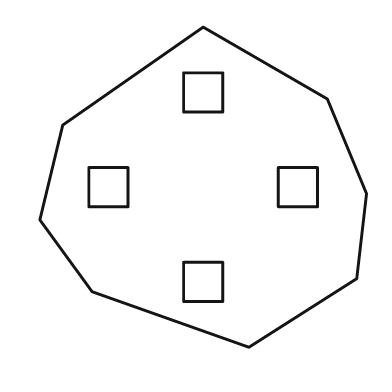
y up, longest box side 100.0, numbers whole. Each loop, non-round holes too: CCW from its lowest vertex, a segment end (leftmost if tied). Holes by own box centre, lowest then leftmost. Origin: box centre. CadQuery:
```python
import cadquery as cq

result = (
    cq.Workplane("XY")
    .moveTo(14.0, -49.0)
    .lineTo(47.0, -28.0)
    .lineTo(50.0, -2.0)
    .lineTo(38.0, 27.0)
    .lineTo(0.0, 49.0)
    .lineTo(-43.0, 19.0)
    .lineTo(-50.0, -10.0)
    .lineTo(-34.0, -32.0)
    .close()
    .moveTo(-6.0, -35.0)
    .lineTo(6.0, -35.0)
    .lineTo(6.0, -23.0)
    .lineTo(-6.0, -23.0)
    .close()
    .moveTo(-35.0, -6.0)
    .lineTo(-23.0, -6.0)
    .lineTo(-23.0, 6.0)
    .lineTo(-35.0, 6.0)
    .close()
    .moveTo(23.0, -6.0)
    .lineTo(35.0, -6.0)
    .lineTo(35.0, 6.0)
    .lineTo(23.0, 6.0)
    .close()
    .moveTo(-6.0, 23.0)
    .lineTo(6.0, 23.0)
    .lineTo(6.0, 35.0)
    .lineTo(-6.0, 35.0)
    .close()
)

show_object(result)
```